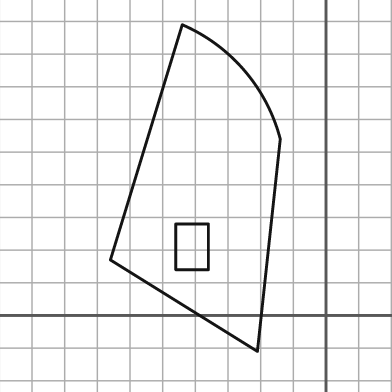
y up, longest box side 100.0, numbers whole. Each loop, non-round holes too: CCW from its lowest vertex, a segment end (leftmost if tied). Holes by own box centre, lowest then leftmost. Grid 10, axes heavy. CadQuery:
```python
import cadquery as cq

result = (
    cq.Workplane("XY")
    .moveTo(-21.0, -11.0)
    .lineTo(-14.0, 54.0)
    .threePointArc((-25.0, 75.0), (-44.0, 89.0))
    .lineTo(-66.0, 17.0)
    .close()
    .moveTo(-46.0, 14.0)
    .lineTo(-36.0, 14.0)
    .lineTo(-36.0, 28.0)
    .lineTo(-46.0, 28.0)
    .close()
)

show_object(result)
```